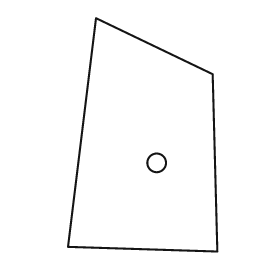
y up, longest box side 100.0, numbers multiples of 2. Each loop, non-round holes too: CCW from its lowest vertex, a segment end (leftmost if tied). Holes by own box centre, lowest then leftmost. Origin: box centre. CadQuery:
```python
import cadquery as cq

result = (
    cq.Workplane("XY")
    .moveTo(32.0, -50.0)
    .lineTo(30.0, 26.0)
    .lineTo(-20.0, 50.0)
    .lineTo(-32.0, -48.0)
    .close()
    .moveTo(6.0, -12.0)
    .circle(4.0)
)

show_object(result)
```